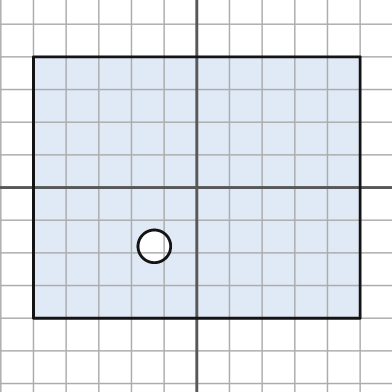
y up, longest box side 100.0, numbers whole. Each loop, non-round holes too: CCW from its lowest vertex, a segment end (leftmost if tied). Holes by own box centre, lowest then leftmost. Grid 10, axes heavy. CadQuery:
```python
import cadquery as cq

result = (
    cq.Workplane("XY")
    .moveTo(-50.0, -40.0)
    .lineTo(50.0, -40.0)
    .lineTo(50.0, 40.0)
    .lineTo(-50.0, 40.0)
    .close()
    .moveTo(-13.0, -18.0)
    .circle(5.0)
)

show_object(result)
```